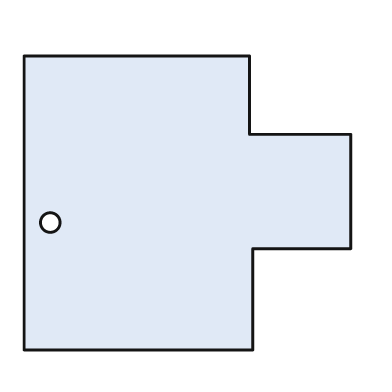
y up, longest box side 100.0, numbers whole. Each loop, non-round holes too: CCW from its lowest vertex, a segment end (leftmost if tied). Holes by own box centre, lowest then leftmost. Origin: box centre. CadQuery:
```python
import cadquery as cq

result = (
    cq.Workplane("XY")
    .moveTo(-50.0, -45.0)
    .lineTo(20.0, -45.0)
    .lineTo(20.0, -14.0)
    .lineTo(50.0, -14.0)
    .lineTo(50.0, 21.0)
    .lineTo(19.0, 21.0)
    .lineTo(19.0, 45.0)
    .lineTo(-50.0, 45.0)
    .close()
    .moveTo(-42.0, -6.0)
    .circle(3.0)
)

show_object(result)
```